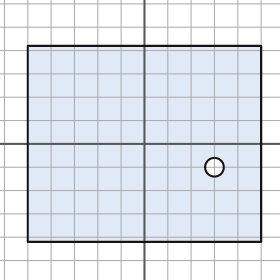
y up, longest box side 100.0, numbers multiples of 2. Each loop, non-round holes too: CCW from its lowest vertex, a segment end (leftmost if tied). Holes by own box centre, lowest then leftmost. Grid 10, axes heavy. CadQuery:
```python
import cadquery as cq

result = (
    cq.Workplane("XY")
    .moveTo(-50.0, -42.0)
    .lineTo(50.0, -42.0)
    .lineTo(50.0, 42.0)
    .lineTo(-50.0, 42.0)
    .close()
    .moveTo(30.0, -10.0)
    .circle(4.0)
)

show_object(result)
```